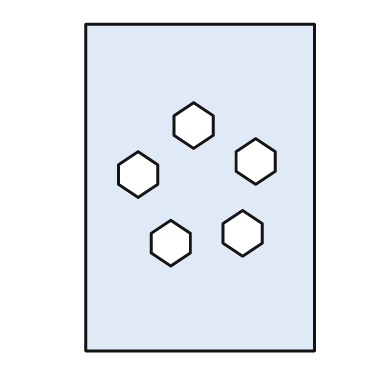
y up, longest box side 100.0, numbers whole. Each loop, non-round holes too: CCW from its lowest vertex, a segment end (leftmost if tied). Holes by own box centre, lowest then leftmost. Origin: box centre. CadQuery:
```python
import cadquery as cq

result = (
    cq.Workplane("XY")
    .moveTo(-35.0, -50.0)
    .lineTo(35.0, -50.0)
    .lineTo(35.0, 50.0)
    .lineTo(-35.0, 50.0)
    .close()
    .moveTo(-9.0, -24.0)
    .lineTo(-3.0, -20.0)
    .lineTo(-3.0, -14.0)
    .lineTo(-9.0, -10.0)
    .lineTo(-15.0, -14.0)
    .lineTo(-15.0, -20.0)
    .close()
    .moveTo(13.0, -21.0)
    .lineTo(19.0, -17.0)
    .lineTo(19.0, -11.0)
    .lineTo(13.0, -7.0)
    .lineTo(7.0, -11.0)
    .lineTo(7.0, -17.0)
    .close()
    .moveTo(-19.0, -3.0)
    .lineTo(-13.0, 1.0)
    .lineTo(-13.0, 7.0)
    .lineTo(-19.0, 11.0)
    .lineTo(-25.0, 7.0)
    .lineTo(-25.0, 1.0)
    .close()
    .moveTo(17.0, 1.0)
    .lineTo(23.0, 5.0)
    .lineTo(23.0, 11.0)
    .lineTo(17.0, 15.0)
    .lineTo(11.0, 11.0)
    .lineTo(11.0, 5.0)
    .close()
    .moveTo(-2.0, 12.0)
    .lineTo(4.0, 16.0)
    .lineTo(4.0, 22.0)
    .lineTo(-2.0, 26.0)
    .lineTo(-8.0, 22.0)
    .lineTo(-8.0, 16.0)
    .close()
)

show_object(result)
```